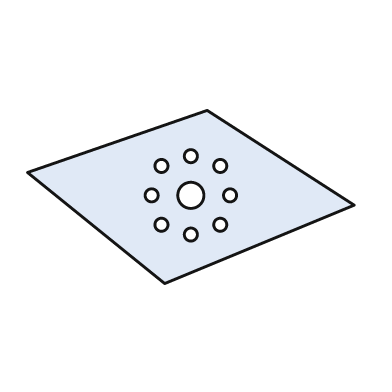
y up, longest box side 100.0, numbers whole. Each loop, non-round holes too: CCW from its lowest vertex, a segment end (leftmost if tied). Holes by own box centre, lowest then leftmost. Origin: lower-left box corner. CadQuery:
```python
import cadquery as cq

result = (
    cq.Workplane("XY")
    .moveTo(42.0, 0.0)
    .lineTo(100.0, 24.0)
    .lineTo(55.0, 53.0)
    .lineTo(0.0, 34.0)
    .close()
    .moveTo(50.0, 15.0)
    .circle(2.0)
    .moveTo(41.0, 18.0)
    .circle(2.0)
    .moveTo(59.0, 18.0)
    .circle(2.0)
    .moveTo(38.0, 27.0)
    .circle(2.0)
    .moveTo(50.0, 27.0)
    .circle(4.0)
    .moveTo(62.0, 27.0)
    .circle(2.0)
    .moveTo(41.0, 36.0)
    .circle(2.0)
    .moveTo(59.0, 36.0)
    .circle(2.0)
    .moveTo(50.0, 39.0)
    .circle(2.0)
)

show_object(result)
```